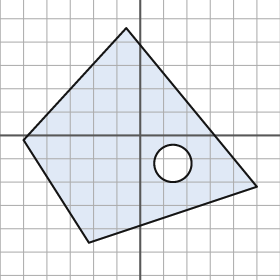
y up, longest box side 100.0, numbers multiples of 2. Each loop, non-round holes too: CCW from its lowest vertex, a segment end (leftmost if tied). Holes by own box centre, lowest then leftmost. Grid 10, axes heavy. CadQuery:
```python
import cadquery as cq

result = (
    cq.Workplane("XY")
    .moveTo(-22.0, -46.0)
    .lineTo(50.0, -22.0)
    .lineTo(-6.0, 46.0)
    .lineTo(-50.0, -2.0)
    .close()
    .moveTo(14.0, -12.0)
    .circle(8.0)
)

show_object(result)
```